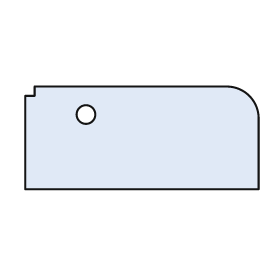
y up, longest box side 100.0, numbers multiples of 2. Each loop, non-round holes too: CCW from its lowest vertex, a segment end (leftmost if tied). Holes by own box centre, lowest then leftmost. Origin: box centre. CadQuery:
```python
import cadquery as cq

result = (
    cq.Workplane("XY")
    .moveTo(-50.0, -22.0)
    .lineTo(50.0, -22.0)
    .lineTo(50.0, 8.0)
    .threePointArc((46.0, 18.0), (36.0, 22.0))
    .lineTo(-46.0, 22.0)
    .lineTo(-46.0, 18.0)
    .lineTo(-50.0, 18.0)
    .close()
    .moveTo(-24.0, 10.0)
    .circle(4.0)
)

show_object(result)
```